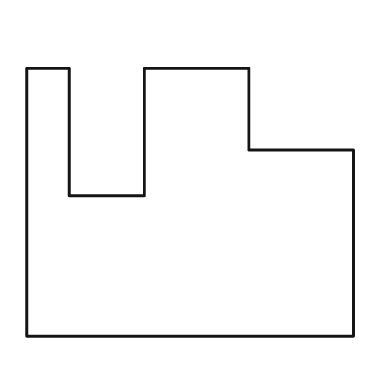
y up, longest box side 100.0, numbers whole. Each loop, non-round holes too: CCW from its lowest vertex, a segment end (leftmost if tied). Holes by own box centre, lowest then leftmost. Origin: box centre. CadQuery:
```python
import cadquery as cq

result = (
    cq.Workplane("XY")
    .moveTo(-50.0, -41.0)
    .lineTo(50.0, -41.0)
    .lineTo(50.0, 16.0)
    .lineTo(18.0, 16.0)
    .lineTo(18.0, 41.0)
    .lineTo(-14.0, 41.0)
    .lineTo(-14.0, 2.0)
    .lineTo(-37.0, 2.0)
    .lineTo(-37.0, 41.0)
    .lineTo(-50.0, 41.0)
    .close()
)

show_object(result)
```